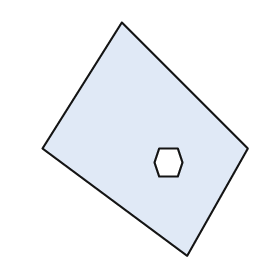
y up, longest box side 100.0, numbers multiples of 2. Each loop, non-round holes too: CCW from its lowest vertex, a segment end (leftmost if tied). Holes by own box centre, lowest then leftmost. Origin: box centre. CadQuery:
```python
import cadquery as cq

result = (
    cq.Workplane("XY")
    .moveTo(18.0, -50.0)
    .lineTo(44.0, -4.0)
    .lineTo(-10.0, 50.0)
    .lineTo(-44.0, -4.0)
    .close()
    .moveTo(6.0, -16.0)
    .lineTo(14.0, -16.0)
    .lineTo(16.0, -10.0)
    .lineTo(14.0, -4.0)
    .lineTo(6.0, -4.0)
    .lineTo(4.0, -10.0)
    .close()
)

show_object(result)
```